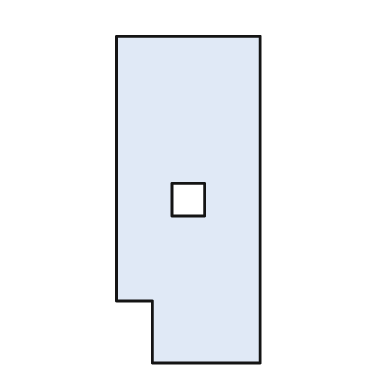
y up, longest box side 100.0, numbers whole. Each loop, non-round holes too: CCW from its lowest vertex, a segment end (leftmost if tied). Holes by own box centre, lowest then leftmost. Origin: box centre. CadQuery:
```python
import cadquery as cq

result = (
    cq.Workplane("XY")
    .moveTo(-11.0, -50.0)
    .lineTo(22.0, -50.0)
    .lineTo(22.0, 50.0)
    .lineTo(-22.0, 50.0)
    .lineTo(-22.0, -31.0)
    .lineTo(-11.0, -31.0)
    .close()
    .moveTo(-5.0, -5.0)
    .lineTo(5.0, -5.0)
    .lineTo(5.0, 5.0)
    .lineTo(-5.0, 5.0)
    .close()
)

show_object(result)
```